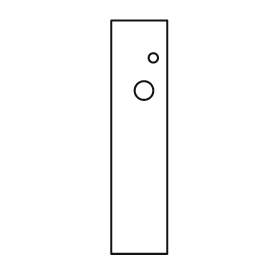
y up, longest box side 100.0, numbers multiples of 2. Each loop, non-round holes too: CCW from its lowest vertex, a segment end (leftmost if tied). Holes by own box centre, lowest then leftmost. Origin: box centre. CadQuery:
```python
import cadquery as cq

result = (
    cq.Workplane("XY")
    .moveTo(-12.0, -50.0)
    .lineTo(12.0, -50.0)
    .lineTo(12.0, 50.0)
    .lineTo(-12.0, 50.0)
    .close()
    .moveTo(2.0, 20.0)
    .circle(4.0)
    .moveTo(6.0, 34.0)
    .circle(2.0)
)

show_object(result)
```